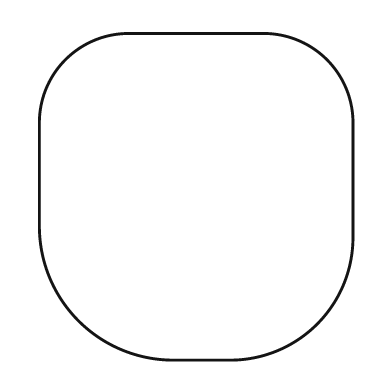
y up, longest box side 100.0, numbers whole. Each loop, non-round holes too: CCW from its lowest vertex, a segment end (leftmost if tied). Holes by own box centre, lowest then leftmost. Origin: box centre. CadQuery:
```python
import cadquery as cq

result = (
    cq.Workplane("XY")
    .moveTo(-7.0, -50.0)
    .lineTo(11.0, -50.0)
    .threePointArc((37.0, -39.0), (48.0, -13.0))
    .lineTo(48.0, 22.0)
    .threePointArc((40.0, 42.0), (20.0, 50.0))
    .lineTo(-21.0, 50.0)
    .threePointArc((-40.0, 42.0), (-48.0, 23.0))
    .lineTo(-48.0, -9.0)
    .threePointArc((-36.0, -38.0), (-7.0, -50.0))
    .close()
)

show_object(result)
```